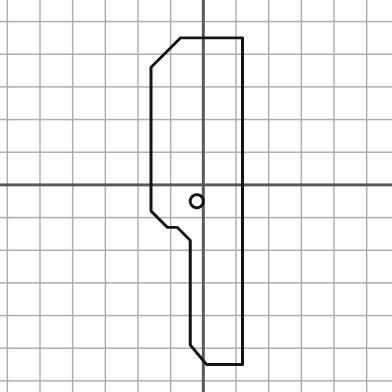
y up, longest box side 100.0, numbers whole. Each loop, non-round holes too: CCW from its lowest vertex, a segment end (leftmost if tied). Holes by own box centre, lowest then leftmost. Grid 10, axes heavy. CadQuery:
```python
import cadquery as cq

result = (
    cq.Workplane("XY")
    .moveTo(1.0, -55.0)
    .lineTo(12.0, -55.0)
    .lineTo(12.0, 45.0)
    .lineTo(-7.0, 45.0)
    .lineTo(-16.0, 36.0)
    .lineTo(-16.0, -8.0)
    .lineTo(-11.0, -13.0)
    .lineTo(-8.0, -13.0)
    .lineTo(-4.0, -17.0)
    .lineTo(-4.0, -49.0)
    .close()
    .moveTo(-2.0, -5.0)
    .circle(2.0)
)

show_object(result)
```